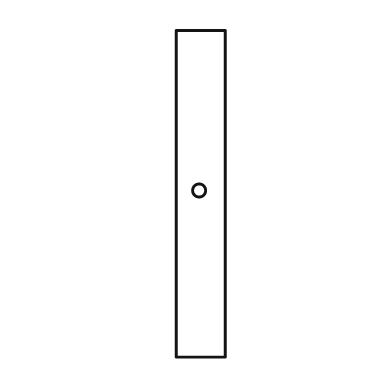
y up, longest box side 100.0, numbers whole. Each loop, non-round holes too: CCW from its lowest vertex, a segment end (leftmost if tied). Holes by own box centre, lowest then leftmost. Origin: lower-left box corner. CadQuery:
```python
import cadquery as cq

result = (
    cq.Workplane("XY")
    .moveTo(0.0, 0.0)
    .lineTo(15.0, 0.0)
    .lineTo(15.0, 100.0)
    .lineTo(0.0, 100.0)
    .close()
    .moveTo(7.0, 51.0)
    .circle(2.0)
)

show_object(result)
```